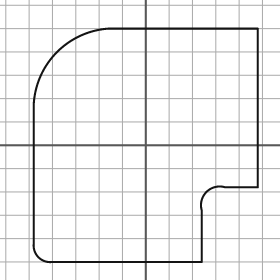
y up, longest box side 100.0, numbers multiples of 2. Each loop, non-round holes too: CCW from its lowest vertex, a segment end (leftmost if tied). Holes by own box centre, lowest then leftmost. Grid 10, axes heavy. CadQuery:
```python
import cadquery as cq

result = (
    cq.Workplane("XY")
    .moveTo(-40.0, -50.0)
    .lineTo(24.0, -50.0)
    .lineTo(24.0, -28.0)
    .threePointArc((26.0, -20.0), (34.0, -18.0))
    .lineTo(48.0, -18.0)
    .lineTo(48.0, 50.0)
    .lineTo(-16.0, 50.0)
    .threePointArc((-38.0, 40.0), (-48.0, 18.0))
    .lineTo(-48.0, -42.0)
    .threePointArc((-46.0, -48.0), (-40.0, -50.0))
    .close()
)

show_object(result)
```